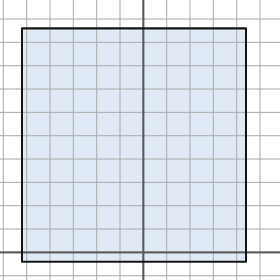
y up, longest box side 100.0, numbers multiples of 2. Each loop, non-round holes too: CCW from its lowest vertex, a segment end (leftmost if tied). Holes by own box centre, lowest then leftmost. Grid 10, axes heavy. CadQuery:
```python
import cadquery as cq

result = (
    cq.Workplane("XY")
    .moveTo(-52.0, -4.0)
    .lineTo(44.0, -4.0)
    .lineTo(44.0, 96.0)
    .lineTo(-52.0, 96.0)
    .close()
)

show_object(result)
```